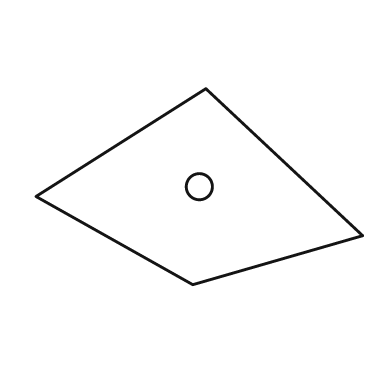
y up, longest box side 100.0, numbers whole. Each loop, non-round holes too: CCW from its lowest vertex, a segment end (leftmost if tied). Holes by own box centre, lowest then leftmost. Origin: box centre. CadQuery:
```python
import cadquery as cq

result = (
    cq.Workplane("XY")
    .moveTo(-2.0, -30.0)
    .lineTo(50.0, -15.0)
    .lineTo(2.0, 30.0)
    .lineTo(-50.0, -3.0)
    .close()
    .moveTo(0.0, 0.0)
    .circle(4.0)
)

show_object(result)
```